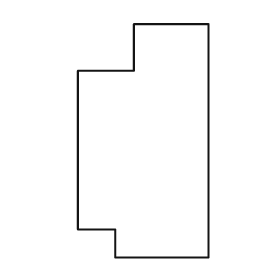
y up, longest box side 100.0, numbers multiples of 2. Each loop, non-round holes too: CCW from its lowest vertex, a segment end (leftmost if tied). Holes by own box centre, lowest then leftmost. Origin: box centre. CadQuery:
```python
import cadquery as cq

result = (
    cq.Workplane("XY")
    .moveTo(-12.0, -50.0)
    .lineTo(28.0, -50.0)
    .lineTo(28.0, 50.0)
    .lineTo(-4.0, 50.0)
    .lineTo(-4.0, 30.0)
    .lineTo(-28.0, 30.0)
    .lineTo(-28.0, -38.0)
    .lineTo(-12.0, -38.0)
    .close()
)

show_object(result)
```